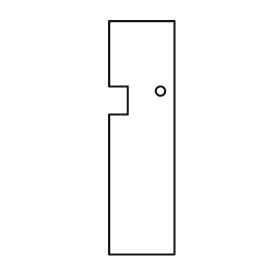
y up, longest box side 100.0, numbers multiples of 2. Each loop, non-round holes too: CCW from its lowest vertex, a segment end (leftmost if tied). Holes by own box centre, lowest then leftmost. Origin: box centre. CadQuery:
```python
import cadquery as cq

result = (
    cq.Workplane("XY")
    .moveTo(-14.0, -50.0)
    .lineTo(14.0, -50.0)
    .lineTo(14.0, 50.0)
    .lineTo(-14.0, 50.0)
    .lineTo(-14.0, 22.0)
    .lineTo(-6.0, 22.0)
    .lineTo(-6.0, 10.0)
    .lineTo(-14.0, 10.0)
    .close()
    .moveTo(8.0, 20.0)
    .circle(2.0)
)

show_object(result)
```